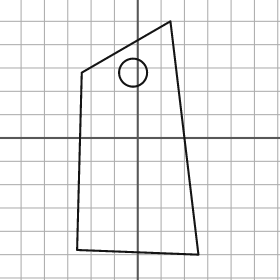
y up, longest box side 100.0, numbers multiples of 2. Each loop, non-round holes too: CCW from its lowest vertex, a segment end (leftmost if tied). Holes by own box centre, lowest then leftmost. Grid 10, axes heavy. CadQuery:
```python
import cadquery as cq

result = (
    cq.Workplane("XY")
    .moveTo(26.0, -50.0)
    .lineTo(14.0, 50.0)
    .lineTo(-24.0, 28.0)
    .lineTo(-26.0, -48.0)
    .close()
    .moveTo(-2.0, 28.0)
    .circle(6.0)
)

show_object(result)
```